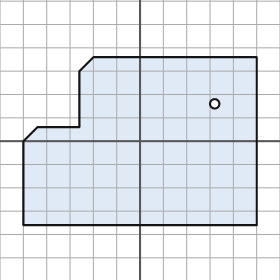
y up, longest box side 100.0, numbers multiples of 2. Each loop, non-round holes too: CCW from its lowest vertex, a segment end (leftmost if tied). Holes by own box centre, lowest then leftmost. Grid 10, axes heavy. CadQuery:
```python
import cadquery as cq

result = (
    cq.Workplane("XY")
    .moveTo(-50.0, -36.0)
    .lineTo(50.0, -36.0)
    .lineTo(50.0, 36.0)
    .lineTo(-20.0, 36.0)
    .lineTo(-26.0, 30.0)
    .lineTo(-26.0, 6.0)
    .lineTo(-44.0, 6.0)
    .lineTo(-50.0, 0.0)
    .close()
    .moveTo(32.0, 16.0)
    .circle(2.0)
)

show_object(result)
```